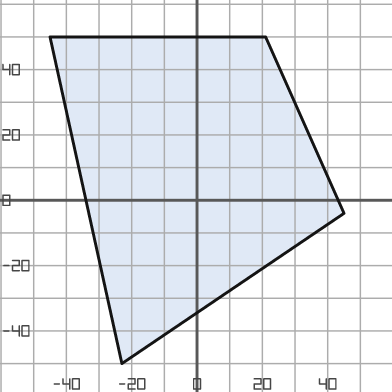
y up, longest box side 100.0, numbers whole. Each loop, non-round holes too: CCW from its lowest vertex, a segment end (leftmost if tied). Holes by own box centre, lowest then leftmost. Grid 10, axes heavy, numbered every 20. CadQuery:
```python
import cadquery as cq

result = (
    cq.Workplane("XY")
    .moveTo(-23.0, -50.0)
    .lineTo(45.0, -4.0)
    .lineTo(21.0, 50.0)
    .lineTo(-45.0, 50.0)
    .close()
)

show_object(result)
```